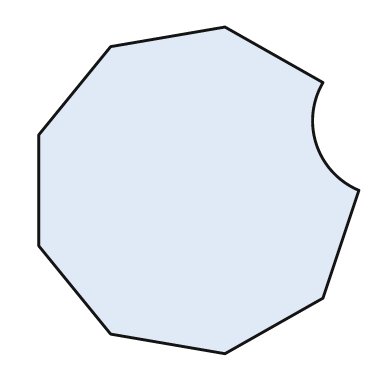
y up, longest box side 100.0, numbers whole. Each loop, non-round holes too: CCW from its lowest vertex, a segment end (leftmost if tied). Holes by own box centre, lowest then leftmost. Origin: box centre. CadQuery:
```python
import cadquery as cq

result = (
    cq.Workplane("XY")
    .moveTo(8.0, -50.0)
    .lineTo(38.0, -33.0)
    .lineTo(49.0, 0.0)
    .threePointArc((36.0, 14.0), (38.0, 33.0))
    .lineTo(8.0, 50.0)
    .lineTo(-27.0, 44.0)
    .lineTo(-49.0, 17.0)
    .lineTo(-49.0, -17.0)
    .lineTo(-27.0, -44.0)
    .close()
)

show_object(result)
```